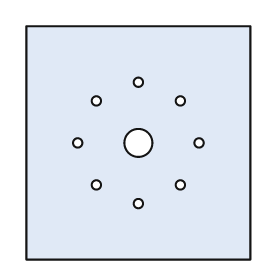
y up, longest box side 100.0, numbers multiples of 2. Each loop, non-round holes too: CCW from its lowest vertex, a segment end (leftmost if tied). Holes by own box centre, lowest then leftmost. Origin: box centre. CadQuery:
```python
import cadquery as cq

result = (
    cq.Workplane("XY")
    .moveTo(-48.0, -50.0)
    .lineTo(48.0, -50.0)
    .lineTo(48.0, 50.0)
    .lineTo(-48.0, 50.0)
    .close()
    .moveTo(0.0, -26.0)
    .circle(2.0)
    .moveTo(-18.0, -18.0)
    .circle(2.0)
    .moveTo(18.0, -18.0)
    .circle(2.0)
    .moveTo(-26.0, 0.0)
    .circle(2.0)
    .moveTo(0.0, 0.0)
    .circle(6.0)
    .moveTo(26.0, 0.0)
    .circle(2.0)
    .moveTo(-18.0, 18.0)
    .circle(2.0)
    .moveTo(18.0, 18.0)
    .circle(2.0)
    .moveTo(0.0, 26.0)
    .circle(2.0)
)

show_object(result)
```